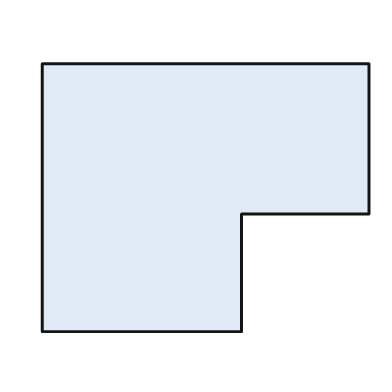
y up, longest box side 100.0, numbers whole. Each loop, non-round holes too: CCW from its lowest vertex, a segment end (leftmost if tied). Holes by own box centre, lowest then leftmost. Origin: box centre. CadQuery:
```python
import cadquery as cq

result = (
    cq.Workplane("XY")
    .moveTo(-50.0, -41.0)
    .lineTo(11.0, -41.0)
    .lineTo(11.0, -5.0)
    .lineTo(50.0, -5.0)
    .lineTo(50.0, 41.0)
    .lineTo(-50.0, 41.0)
    .close()
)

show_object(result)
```